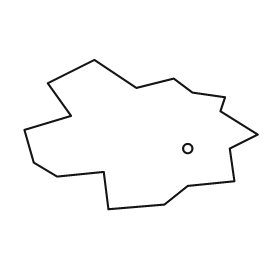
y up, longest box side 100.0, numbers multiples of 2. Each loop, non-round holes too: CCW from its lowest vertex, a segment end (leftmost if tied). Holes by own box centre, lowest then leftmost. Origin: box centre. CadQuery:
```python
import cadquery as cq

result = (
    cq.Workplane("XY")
    .moveTo(-14.0, -32.0)
    .lineTo(10.0, -30.0)
    .lineTo(20.0, -22.0)
    .lineTo(40.0, -20.0)
    .lineTo(38.0, -6.0)
    .lineTo(50.0, 0.0)
    .lineTo(34.0, 10.0)
    .lineTo(36.0, 16.0)
    .lineTo(22.0, 18.0)
    .lineTo(14.0, 24.0)
    .lineTo(-2.0, 20.0)
    .lineTo(-20.0, 32.0)
    .lineTo(-40.0, 22.0)
    .lineTo(-30.0, 8.0)
    .lineTo(-50.0, 2.0)
    .lineTo(-46.0, -12.0)
    .lineTo(-36.0, -18.0)
    .lineTo(-16.0, -16.0)
    .close()
    .moveTo(20.0, -6.0)
    .circle(2.0)
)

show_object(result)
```